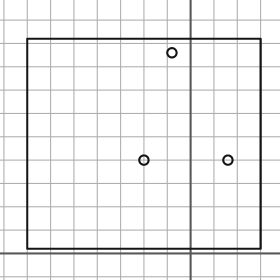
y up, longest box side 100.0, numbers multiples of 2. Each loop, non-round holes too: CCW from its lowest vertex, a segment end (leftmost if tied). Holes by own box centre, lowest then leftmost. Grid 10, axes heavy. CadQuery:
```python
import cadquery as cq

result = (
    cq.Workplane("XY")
    .moveTo(-70.0, 2.0)
    .lineTo(30.0, 2.0)
    .lineTo(30.0, 92.0)
    .lineTo(-70.0, 92.0)
    .close()
    .moveTo(-20.0, 40.0)
    .circle(2.0)
    .moveTo(16.0, 40.0)
    .circle(2.0)
    .moveTo(-8.0, 86.0)
    .circle(2.0)
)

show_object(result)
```